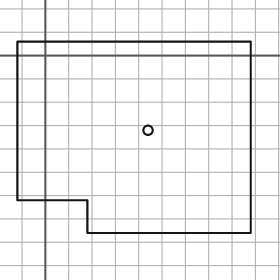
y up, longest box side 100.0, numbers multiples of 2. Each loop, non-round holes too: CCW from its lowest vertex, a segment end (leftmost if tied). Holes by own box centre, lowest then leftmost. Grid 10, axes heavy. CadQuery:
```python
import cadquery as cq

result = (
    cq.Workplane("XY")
    .moveTo(18.0, -76.0)
    .lineTo(88.0, -76.0)
    .lineTo(88.0, 6.0)
    .lineTo(-12.0, 6.0)
    .lineTo(-12.0, -62.0)
    .lineTo(18.0, -62.0)
    .close()
    .moveTo(44.0, -32.0)
    .circle(2.0)
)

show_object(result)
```